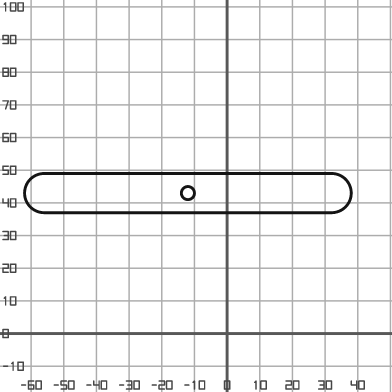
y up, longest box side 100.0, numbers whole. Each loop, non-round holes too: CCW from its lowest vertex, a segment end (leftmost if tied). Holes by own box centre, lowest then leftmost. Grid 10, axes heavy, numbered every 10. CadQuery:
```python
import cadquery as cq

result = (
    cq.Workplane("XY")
    .moveTo(-56.0, 37.0)
    .lineTo(32.0, 37.0)
    .threePointArc((38.0, 43.0), (32.0, 49.0))
    .lineTo(-56.0, 49.0)
    .threePointArc((-62.0, 43.0), (-56.0, 37.0))
    .close()
    .moveTo(-12.0, 43.0)
    .circle(2.0)
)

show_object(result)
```